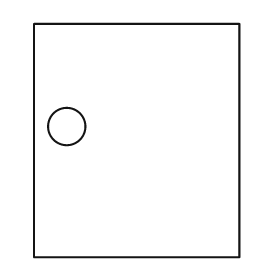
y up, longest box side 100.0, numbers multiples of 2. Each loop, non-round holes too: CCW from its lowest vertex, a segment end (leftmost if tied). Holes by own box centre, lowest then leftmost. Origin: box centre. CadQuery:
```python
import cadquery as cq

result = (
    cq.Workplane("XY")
    .moveTo(-44.0, -50.0)
    .lineTo(44.0, -50.0)
    .lineTo(44.0, 50.0)
    .lineTo(-44.0, 50.0)
    .close()
    .moveTo(-30.0, 6.0)
    .circle(8.0)
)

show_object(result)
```